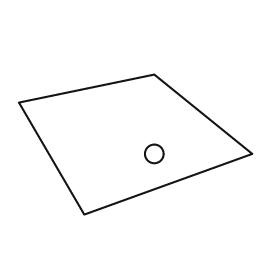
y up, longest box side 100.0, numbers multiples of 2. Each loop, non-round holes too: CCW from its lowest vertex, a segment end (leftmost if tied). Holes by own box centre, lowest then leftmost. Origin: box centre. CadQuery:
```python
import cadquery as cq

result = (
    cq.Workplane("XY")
    .moveTo(-22.0, -30.0)
    .lineTo(50.0, -4.0)
    .lineTo(8.0, 30.0)
    .lineTo(-50.0, 18.0)
    .close()
    .moveTo(8.0, -4.0)
    .circle(4.0)
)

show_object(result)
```